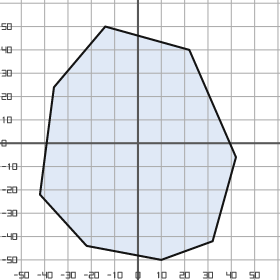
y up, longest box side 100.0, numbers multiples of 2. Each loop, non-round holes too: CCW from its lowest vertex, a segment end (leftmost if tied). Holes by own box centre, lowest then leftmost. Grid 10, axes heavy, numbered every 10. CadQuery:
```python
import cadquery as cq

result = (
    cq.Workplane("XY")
    .moveTo(10.0, -50.0)
    .lineTo(32.0, -42.0)
    .lineTo(42.0, -6.0)
    .lineTo(22.0, 40.0)
    .lineTo(-14.0, 50.0)
    .lineTo(-36.0, 24.0)
    .lineTo(-42.0, -22.0)
    .lineTo(-22.0, -44.0)
    .close()
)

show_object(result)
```